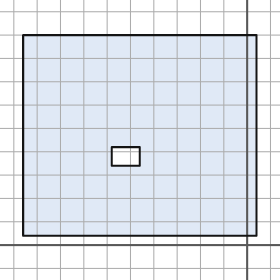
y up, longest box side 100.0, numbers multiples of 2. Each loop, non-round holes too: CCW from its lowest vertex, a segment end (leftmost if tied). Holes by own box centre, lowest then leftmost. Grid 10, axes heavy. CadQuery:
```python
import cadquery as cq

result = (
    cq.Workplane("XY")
    .moveTo(-96.0, 4.0)
    .lineTo(4.0, 4.0)
    .lineTo(4.0, 90.0)
    .lineTo(-96.0, 90.0)
    .close()
    .moveTo(-58.0, 34.0)
    .lineTo(-46.0, 34.0)
    .lineTo(-46.0, 42.0)
    .lineTo(-58.0, 42.0)
    .close()
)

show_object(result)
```